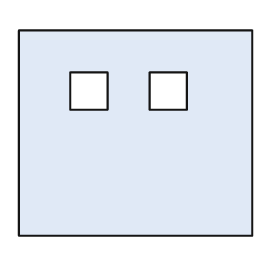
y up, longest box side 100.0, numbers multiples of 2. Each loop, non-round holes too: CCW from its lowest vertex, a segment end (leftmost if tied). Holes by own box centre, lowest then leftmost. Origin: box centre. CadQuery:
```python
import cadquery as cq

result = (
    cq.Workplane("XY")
    .moveTo(-50.0, -44.0)
    .lineTo(50.0, -44.0)
    .lineTo(50.0, 44.0)
    .lineTo(-50.0, 44.0)
    .close()
    .moveTo(-28.0, 10.0)
    .lineTo(-12.0, 10.0)
    .lineTo(-12.0, 26.0)
    .lineTo(-28.0, 26.0)
    .close()
    .moveTo(6.0, 10.0)
    .lineTo(22.0, 10.0)
    .lineTo(22.0, 26.0)
    .lineTo(6.0, 26.0)
    .close()
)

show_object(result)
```